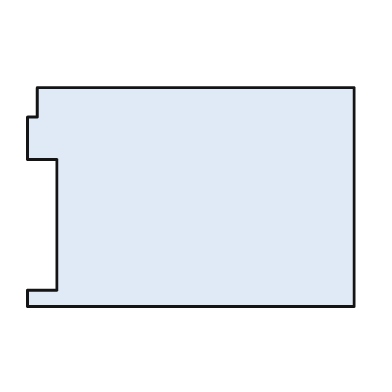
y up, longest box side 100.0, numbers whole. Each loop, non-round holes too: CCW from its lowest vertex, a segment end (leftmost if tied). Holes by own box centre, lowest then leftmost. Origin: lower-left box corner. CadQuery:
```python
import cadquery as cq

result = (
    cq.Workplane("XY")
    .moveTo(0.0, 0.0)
    .lineTo(100.0, 0.0)
    .lineTo(100.0, 67.0)
    .lineTo(3.0, 67.0)
    .lineTo(3.0, 58.0)
    .lineTo(0.0, 58.0)
    .lineTo(0.0, 45.0)
    .lineTo(9.0, 45.0)
    .lineTo(9.0, 5.0)
    .lineTo(0.0, 5.0)
    .close()
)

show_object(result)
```